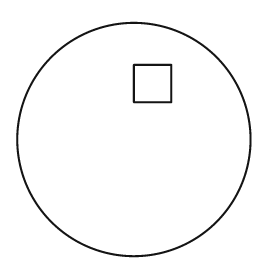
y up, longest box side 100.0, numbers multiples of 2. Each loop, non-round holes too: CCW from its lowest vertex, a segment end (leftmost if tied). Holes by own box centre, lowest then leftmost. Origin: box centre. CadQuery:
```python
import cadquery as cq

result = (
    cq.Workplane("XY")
    .moveTo(0.0, 0.0)
    .circle(50.0)
    .moveTo(0.0, 16.0)
    .lineTo(16.0, 16.0)
    .lineTo(16.0, 32.0)
    .lineTo(0.0, 32.0)
    .close()
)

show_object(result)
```